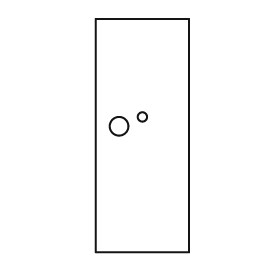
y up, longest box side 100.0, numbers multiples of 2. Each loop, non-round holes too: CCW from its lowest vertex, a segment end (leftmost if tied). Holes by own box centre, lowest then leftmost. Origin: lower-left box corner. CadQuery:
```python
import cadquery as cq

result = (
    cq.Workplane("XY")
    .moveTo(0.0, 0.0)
    .lineTo(40.0, 0.0)
    .lineTo(40.0, 100.0)
    .lineTo(0.0, 100.0)
    .close()
    .moveTo(10.0, 54.0)
    .circle(4.0)
    .moveTo(20.0, 58.0)
    .circle(2.0)
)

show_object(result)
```